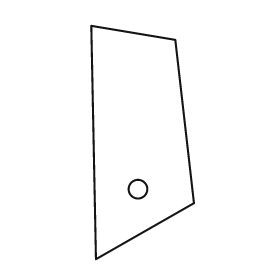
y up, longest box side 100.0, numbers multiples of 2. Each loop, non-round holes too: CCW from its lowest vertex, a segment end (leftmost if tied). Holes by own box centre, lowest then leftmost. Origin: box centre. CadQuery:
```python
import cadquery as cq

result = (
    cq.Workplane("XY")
    .moveTo(-20.0, -50.0)
    .lineTo(22.0, -26.0)
    .lineTo(14.0, 44.0)
    .lineTo(-22.0, 50.0)
    .close()
    .moveTo(-2.0, -20.0)
    .circle(4.0)
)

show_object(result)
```